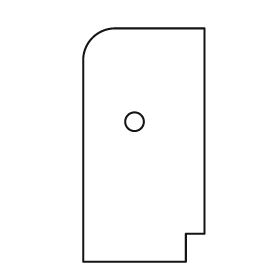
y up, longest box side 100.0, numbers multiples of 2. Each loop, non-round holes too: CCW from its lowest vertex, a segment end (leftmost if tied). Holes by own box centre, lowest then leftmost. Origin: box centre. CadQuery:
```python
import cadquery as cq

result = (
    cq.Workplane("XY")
    .moveTo(-26.0, -50.0)
    .lineTo(18.0, -50.0)
    .lineTo(18.0, -38.0)
    .lineTo(26.0, -38.0)
    .lineTo(26.0, 50.0)
    .lineTo(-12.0, 50.0)
    .threePointArc((-22.0, 46.0), (-26.0, 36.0))
    .close()
    .moveTo(-4.0, 10.0)
    .circle(4.0)
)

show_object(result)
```